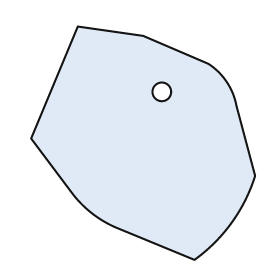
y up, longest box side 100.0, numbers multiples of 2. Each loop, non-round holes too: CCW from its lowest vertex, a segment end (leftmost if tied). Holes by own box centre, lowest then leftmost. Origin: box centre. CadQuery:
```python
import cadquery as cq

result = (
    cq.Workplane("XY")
    .moveTo(22.0, -50.0)
    .threePointArc((38.0, -34.0), (48.0, -14.0))
    .lineTo(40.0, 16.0)
    .threePointArc((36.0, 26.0), (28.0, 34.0))
    .lineTo(0.0, 46.0)
    .lineTo(-28.0, 50.0)
    .lineTo(-48.0, 2.0)
    .lineTo(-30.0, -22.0)
    .threePointArc((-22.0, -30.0), (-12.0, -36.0))
    .close()
    .moveTo(8.0, 22.0)
    .circle(4.0)
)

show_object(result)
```